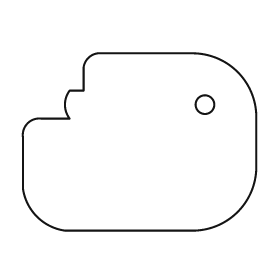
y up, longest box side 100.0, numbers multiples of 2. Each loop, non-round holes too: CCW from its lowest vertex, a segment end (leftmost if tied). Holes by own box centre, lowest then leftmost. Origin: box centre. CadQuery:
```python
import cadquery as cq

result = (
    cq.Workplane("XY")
    .moveTo(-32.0, -38.0)
    .lineTo(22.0, -38.0)
    .threePointArc((42.0, -30.0), (50.0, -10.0))
    .lineTo(50.0, 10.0)
    .threePointArc((42.0, 30.0), (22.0, 38.0))
    .lineTo(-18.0, 38.0)
    .threePointArc((-22.0, 36.0), (-24.0, 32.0))
    .lineTo(-24.0, 22.0)
    .lineTo(-30.0, 22.0)
    .threePointArc((-32.0, 16.0), (-30.0, 10.0))
    .lineTo(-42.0, 10.0)
    .threePointArc((-48.0, 8.0), (-50.0, 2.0))
    .lineTo(-50.0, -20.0)
    .threePointArc((-44.0, -32.0), (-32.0, -38.0))
    .close()
    .moveTo(28.0, 16.0)
    .circle(4.0)
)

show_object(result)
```